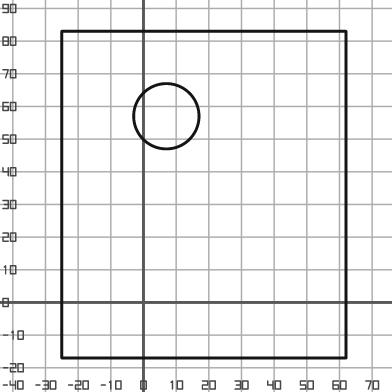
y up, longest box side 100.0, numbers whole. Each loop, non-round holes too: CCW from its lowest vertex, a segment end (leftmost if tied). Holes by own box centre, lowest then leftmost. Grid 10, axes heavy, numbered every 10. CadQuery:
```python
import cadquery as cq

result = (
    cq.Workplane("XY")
    .moveTo(-25.0, -17.0)
    .lineTo(62.0, -17.0)
    .lineTo(62.0, 83.0)
    .lineTo(-25.0, 83.0)
    .close()
    .moveTo(7.0, 57.0)
    .circle(10.0)
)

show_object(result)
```